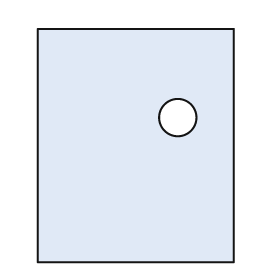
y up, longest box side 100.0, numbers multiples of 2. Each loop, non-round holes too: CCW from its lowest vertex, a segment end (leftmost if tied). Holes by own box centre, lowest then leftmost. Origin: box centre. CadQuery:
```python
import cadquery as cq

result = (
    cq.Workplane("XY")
    .moveTo(-42.0, -50.0)
    .lineTo(42.0, -50.0)
    .lineTo(42.0, 50.0)
    .lineTo(-42.0, 50.0)
    .close()
    .moveTo(18.0, 12.0)
    .circle(8.0)
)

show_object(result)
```